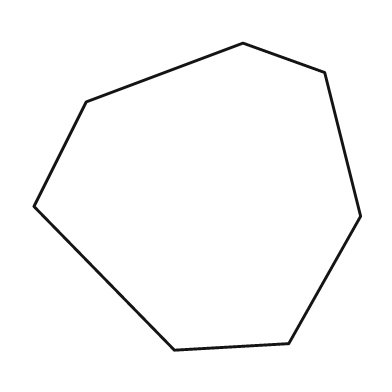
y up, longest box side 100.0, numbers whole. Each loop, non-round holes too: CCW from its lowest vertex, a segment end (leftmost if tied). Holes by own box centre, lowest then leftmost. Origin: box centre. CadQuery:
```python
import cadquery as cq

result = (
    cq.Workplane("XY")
    .moveTo(-7.0, -47.0)
    .lineTo(28.0, -45.0)
    .lineTo(50.0, -6.0)
    .lineTo(39.0, 38.0)
    .lineTo(14.0, 47.0)
    .lineTo(-34.0, 29.0)
    .lineTo(-50.0, -3.0)
    .close()
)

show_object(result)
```